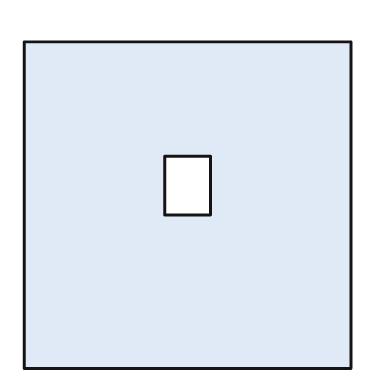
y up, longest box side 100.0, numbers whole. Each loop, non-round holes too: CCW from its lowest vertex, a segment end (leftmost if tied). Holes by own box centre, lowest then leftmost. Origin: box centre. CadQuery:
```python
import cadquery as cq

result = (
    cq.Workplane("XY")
    .moveTo(-50.0, -50.0)
    .lineTo(50.0, -50.0)
    .lineTo(50.0, 50.0)
    .lineTo(-50.0, 50.0)
    .close()
    .moveTo(-7.0, -3.0)
    .lineTo(7.0, -3.0)
    .lineTo(7.0, 15.0)
    .lineTo(-7.0, 15.0)
    .close()
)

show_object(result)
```